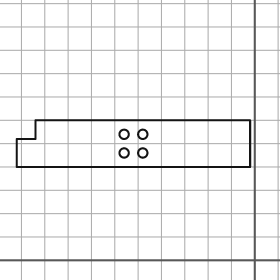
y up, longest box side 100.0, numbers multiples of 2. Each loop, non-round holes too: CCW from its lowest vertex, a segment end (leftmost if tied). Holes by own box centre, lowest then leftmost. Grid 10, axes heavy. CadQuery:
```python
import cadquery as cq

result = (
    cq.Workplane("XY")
    .moveTo(-102.0, 40.0)
    .lineTo(-2.0, 40.0)
    .lineTo(-2.0, 60.0)
    .lineTo(-94.0, 60.0)
    .lineTo(-94.0, 52.0)
    .lineTo(-102.0, 52.0)
    .close()
    .moveTo(-56.0, 46.0)
    .circle(2.0)
    .moveTo(-48.0, 46.0)
    .circle(2.0)
    .moveTo(-56.0, 54.0)
    .circle(2.0)
    .moveTo(-48.0, 54.0)
    .circle(2.0)
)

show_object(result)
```